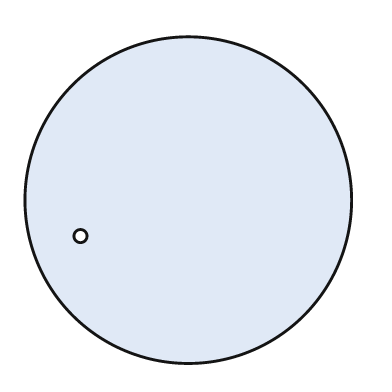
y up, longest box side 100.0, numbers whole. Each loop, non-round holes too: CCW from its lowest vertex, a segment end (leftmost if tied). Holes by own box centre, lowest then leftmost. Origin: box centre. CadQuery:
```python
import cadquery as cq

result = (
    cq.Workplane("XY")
    .moveTo(0.0, 0.0)
    .circle(50.0)
    .moveTo(-33.0, -11.0)
    .circle(2.0)
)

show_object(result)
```